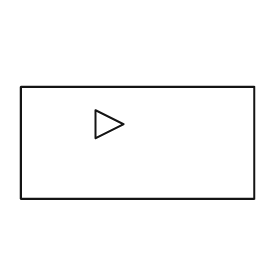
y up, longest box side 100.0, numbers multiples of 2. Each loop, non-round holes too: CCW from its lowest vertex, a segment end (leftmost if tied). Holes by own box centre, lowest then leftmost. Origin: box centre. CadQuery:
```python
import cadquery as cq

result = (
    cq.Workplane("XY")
    .moveTo(-50.0, -24.0)
    .lineTo(50.0, -24.0)
    .lineTo(50.0, 24.0)
    .lineTo(-50.0, 24.0)
    .close()
    .moveTo(-18.0, 2.0)
    .lineTo(-6.0, 8.0)
    .lineTo(-18.0, 14.0)
    .close()
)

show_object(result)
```